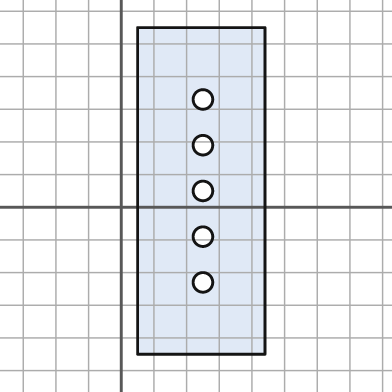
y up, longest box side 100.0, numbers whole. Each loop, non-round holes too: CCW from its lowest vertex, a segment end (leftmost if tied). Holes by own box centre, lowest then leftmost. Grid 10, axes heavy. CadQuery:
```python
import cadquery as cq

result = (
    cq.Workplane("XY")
    .moveTo(5.0, -45.0)
    .lineTo(44.0, -45.0)
    .lineTo(44.0, 55.0)
    .lineTo(5.0, 55.0)
    .close()
    .moveTo(25.0, -23.0)
    .circle(3.0)
    .moveTo(25.0, -9.0)
    .circle(3.0)
    .moveTo(25.0, 5.0)
    .circle(3.0)
    .moveTo(25.0, 19.0)
    .circle(3.0)
    .moveTo(25.0, 33.0)
    .circle(3.0)
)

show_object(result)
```